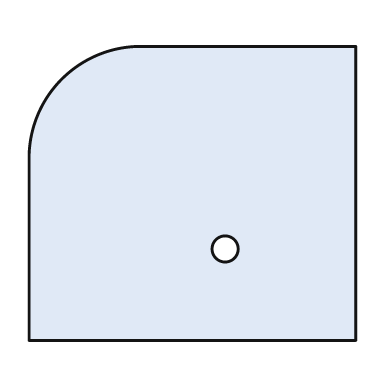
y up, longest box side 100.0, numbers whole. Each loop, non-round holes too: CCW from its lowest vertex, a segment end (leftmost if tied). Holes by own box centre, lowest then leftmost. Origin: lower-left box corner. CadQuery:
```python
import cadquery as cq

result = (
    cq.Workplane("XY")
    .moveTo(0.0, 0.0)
    .lineTo(100.0, 0.0)
    .lineTo(100.0, 90.0)
    .lineTo(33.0, 90.0)
    .threePointArc((10.0, 80.0), (0.0, 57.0))
    .close()
    .moveTo(60.0, 28.0)
    .circle(4.0)
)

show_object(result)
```